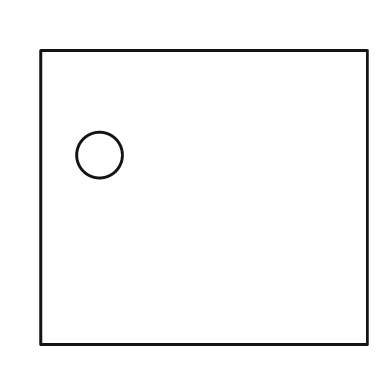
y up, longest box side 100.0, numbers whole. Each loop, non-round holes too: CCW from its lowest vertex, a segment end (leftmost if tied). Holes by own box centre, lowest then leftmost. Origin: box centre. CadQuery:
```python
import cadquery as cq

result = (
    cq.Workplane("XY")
    .moveTo(-50.0, -45.0)
    .lineTo(50.0, -45.0)
    .lineTo(50.0, 45.0)
    .lineTo(-50.0, 45.0)
    .close()
    .moveTo(-32.0, 13.0)
    .circle(7.0)
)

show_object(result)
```